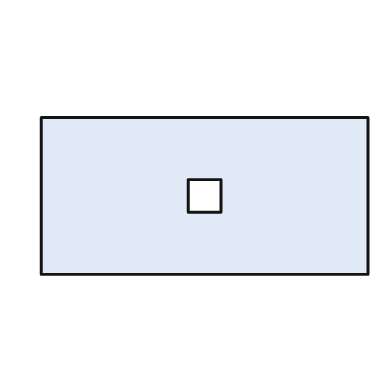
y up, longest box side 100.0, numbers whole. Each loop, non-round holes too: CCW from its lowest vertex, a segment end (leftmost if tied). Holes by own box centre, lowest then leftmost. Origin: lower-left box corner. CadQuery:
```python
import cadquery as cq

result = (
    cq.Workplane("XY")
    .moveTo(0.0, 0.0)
    .lineTo(100.0, 0.0)
    .lineTo(100.0, 48.0)
    .lineTo(0.0, 48.0)
    .close()
    .moveTo(45.0, 19.0)
    .lineTo(55.0, 19.0)
    .lineTo(55.0, 29.0)
    .lineTo(45.0, 29.0)
    .close()
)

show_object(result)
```